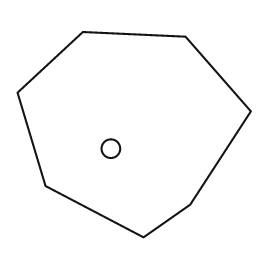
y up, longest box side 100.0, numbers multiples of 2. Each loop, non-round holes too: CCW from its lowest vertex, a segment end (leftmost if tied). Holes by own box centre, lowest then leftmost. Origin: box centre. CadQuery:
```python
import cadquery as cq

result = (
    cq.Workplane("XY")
    .moveTo(4.0, -44.0)
    .lineTo(24.0, -30.0)
    .lineTo(50.0, 10.0)
    .lineTo(22.0, 42.0)
    .lineTo(-22.0, 44.0)
    .lineTo(-50.0, 18.0)
    .lineTo(-38.0, -22.0)
    .close()
    .moveTo(-10.0, -6.0)
    .circle(4.0)
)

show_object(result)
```